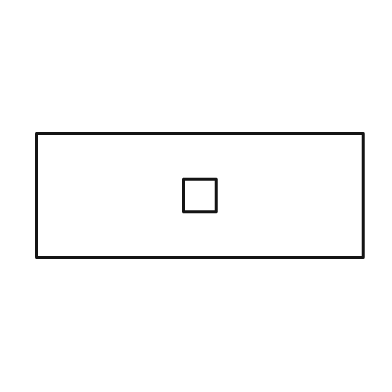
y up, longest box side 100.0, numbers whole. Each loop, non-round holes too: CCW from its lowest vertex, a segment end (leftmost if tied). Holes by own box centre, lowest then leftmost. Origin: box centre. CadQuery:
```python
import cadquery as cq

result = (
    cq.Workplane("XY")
    .moveTo(-50.0, -19.0)
    .lineTo(50.0, -19.0)
    .lineTo(50.0, 19.0)
    .lineTo(-50.0, 19.0)
    .close()
    .moveTo(-5.0, -5.0)
    .lineTo(5.0, -5.0)
    .lineTo(5.0, 5.0)
    .lineTo(-5.0, 5.0)
    .close()
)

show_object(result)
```